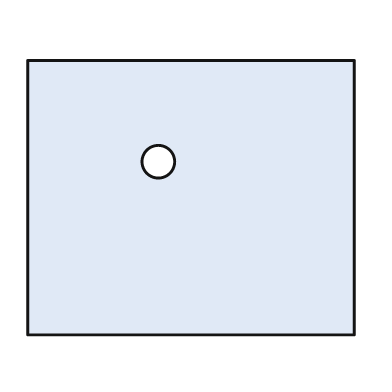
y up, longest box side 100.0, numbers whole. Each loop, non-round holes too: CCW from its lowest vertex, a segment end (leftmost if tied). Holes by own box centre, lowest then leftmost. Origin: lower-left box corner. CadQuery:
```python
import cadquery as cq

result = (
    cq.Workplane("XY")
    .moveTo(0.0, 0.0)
    .lineTo(100.0, 0.0)
    .lineTo(100.0, 84.0)
    .lineTo(0.0, 84.0)
    .close()
    .moveTo(40.0, 53.0)
    .circle(5.0)
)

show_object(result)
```